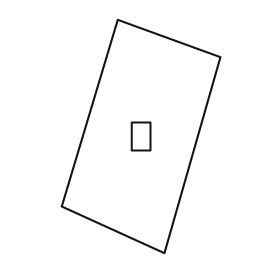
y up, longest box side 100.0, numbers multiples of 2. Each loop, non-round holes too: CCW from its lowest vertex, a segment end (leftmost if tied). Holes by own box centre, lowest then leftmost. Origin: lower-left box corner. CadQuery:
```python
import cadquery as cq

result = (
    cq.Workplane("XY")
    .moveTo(44.0, 0.0)
    .lineTo(68.0, 84.0)
    .lineTo(24.0, 100.0)
    .lineTo(0.0, 20.0)
    .close()
    .moveTo(30.0, 44.0)
    .lineTo(38.0, 44.0)
    .lineTo(38.0, 56.0)
    .lineTo(30.0, 56.0)
    .close()
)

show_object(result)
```